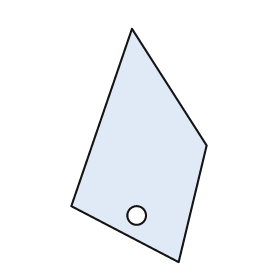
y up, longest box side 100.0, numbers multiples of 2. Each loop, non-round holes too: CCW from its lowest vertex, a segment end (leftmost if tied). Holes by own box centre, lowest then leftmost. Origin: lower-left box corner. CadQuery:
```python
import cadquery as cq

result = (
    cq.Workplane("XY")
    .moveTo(46.0, 0.0)
    .lineTo(58.0, 50.0)
    .lineTo(26.0, 100.0)
    .lineTo(0.0, 24.0)
    .close()
    .moveTo(28.0, 20.0)
    .circle(4.0)
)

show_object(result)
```